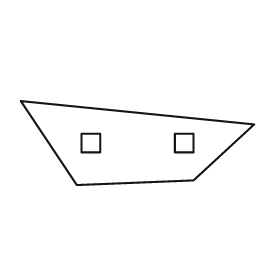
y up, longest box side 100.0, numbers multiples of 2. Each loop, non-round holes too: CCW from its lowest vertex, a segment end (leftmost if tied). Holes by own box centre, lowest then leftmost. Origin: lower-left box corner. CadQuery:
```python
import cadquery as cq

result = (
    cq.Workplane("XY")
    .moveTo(24.0, 0.0)
    .lineTo(74.0, 2.0)
    .lineTo(100.0, 26.0)
    .lineTo(0.0, 36.0)
    .close()
    .moveTo(26.0, 14.0)
    .lineTo(34.0, 14.0)
    .lineTo(34.0, 22.0)
    .lineTo(26.0, 22.0)
    .close()
    .moveTo(66.0, 14.0)
    .lineTo(74.0, 14.0)
    .lineTo(74.0, 22.0)
    .lineTo(66.0, 22.0)
    .close()
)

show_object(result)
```